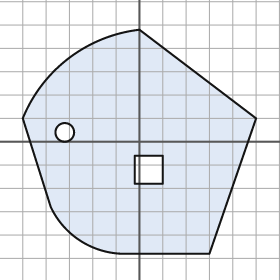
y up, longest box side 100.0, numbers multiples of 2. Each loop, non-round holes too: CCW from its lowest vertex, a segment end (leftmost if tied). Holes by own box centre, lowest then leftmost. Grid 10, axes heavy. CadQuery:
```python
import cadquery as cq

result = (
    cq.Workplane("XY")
    .moveTo(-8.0, -48.0)
    .lineTo(30.0, -48.0)
    .lineTo(50.0, 10.0)
    .lineTo(0.0, 48.0)
    .threePointArc((-30.0, 36.0), (-50.0, 10.0))
    .lineTo(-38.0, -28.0)
    .threePointArc((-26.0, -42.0), (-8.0, -48.0))
    .close()
    .moveTo(-2.0, -18.0)
    .lineTo(10.0, -18.0)
    .lineTo(10.0, -6.0)
    .lineTo(-2.0, -6.0)
    .close()
    .moveTo(-32.0, 4.0)
    .circle(4.0)
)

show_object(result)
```